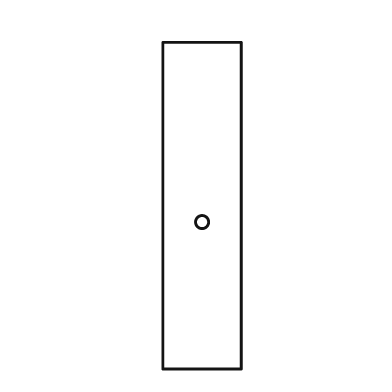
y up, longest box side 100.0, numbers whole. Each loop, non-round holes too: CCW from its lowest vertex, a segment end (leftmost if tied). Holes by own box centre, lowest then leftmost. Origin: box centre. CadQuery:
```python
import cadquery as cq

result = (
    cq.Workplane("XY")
    .moveTo(-12.0, -50.0)
    .lineTo(12.0, -50.0)
    .lineTo(12.0, 50.0)
    .lineTo(-12.0, 50.0)
    .close()
    .moveTo(0.0, -5.0)
    .circle(2.0)
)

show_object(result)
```